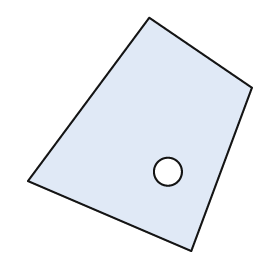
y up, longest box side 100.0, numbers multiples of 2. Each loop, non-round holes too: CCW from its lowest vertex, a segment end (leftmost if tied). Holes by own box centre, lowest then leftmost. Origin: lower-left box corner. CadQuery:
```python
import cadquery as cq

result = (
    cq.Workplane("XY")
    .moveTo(70.0, 0.0)
    .lineTo(96.0, 70.0)
    .lineTo(52.0, 100.0)
    .lineTo(0.0, 30.0)
    .close()
    .moveTo(60.0, 34.0)
    .circle(6.0)
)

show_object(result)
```